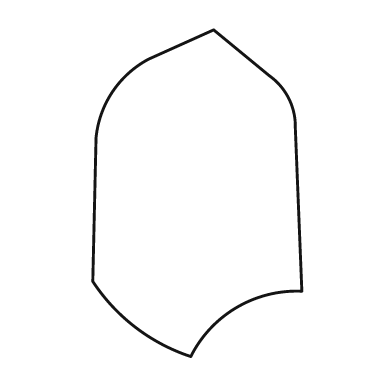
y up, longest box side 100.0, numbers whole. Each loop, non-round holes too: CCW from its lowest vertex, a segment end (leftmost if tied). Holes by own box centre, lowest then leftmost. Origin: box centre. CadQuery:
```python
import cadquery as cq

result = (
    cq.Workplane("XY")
    .moveTo(-2.0, -50.0)
    .threePointArc((12.0, -35.0), (32.0, -30.0))
    .lineTo(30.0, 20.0)
    .threePointArc((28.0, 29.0), (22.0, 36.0))
    .lineTo(5.0, 50.0)
    .lineTo(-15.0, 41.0)
    .threePointArc((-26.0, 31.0), (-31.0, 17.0))
    .lineTo(-32.0, -27.0)
    .threePointArc((-19.0, -41.0), (-2.0, -50.0))
    .close()
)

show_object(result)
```